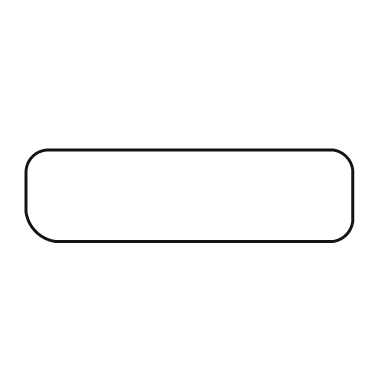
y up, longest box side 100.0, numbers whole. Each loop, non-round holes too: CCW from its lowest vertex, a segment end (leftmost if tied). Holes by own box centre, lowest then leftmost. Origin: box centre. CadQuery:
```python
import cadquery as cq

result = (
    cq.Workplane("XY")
    .moveTo(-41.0, -14.0)
    .lineTo(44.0, -14.0)
    .threePointArc((48.0, -12.0), (50.0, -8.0))
    .lineTo(50.0, 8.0)
    .threePointArc((48.0, 12.0), (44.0, 14.0))
    .lineTo(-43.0, 14.0)
    .threePointArc((-48.0, 12.0), (-50.0, 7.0))
    .lineTo(-50.0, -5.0)
    .threePointArc((-47.0, -11.0), (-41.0, -14.0))
    .close()
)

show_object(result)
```